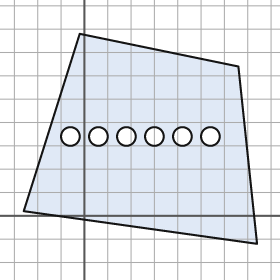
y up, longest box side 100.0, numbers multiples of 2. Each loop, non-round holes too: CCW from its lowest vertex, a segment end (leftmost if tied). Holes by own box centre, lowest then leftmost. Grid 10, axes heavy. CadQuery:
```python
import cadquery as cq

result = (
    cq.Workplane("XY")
    .moveTo(74.0, -12.0)
    .lineTo(66.0, 64.0)
    .lineTo(-2.0, 78.0)
    .lineTo(-26.0, 2.0)
    .close()
    .moveTo(-6.0, 34.0)
    .circle(4.0)
    .moveTo(6.0, 34.0)
    .circle(4.0)
    .moveTo(18.0, 34.0)
    .circle(4.0)
    .moveTo(30.0, 34.0)
    .circle(4.0)
    .moveTo(42.0, 34.0)
    .circle(4.0)
    .moveTo(54.0, 34.0)
    .circle(4.0)
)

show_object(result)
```